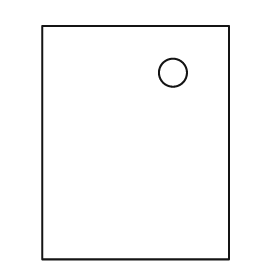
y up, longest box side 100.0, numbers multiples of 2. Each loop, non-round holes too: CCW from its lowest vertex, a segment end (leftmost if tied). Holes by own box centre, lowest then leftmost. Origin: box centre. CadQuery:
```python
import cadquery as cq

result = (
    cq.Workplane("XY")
    .moveTo(-40.0, -50.0)
    .lineTo(40.0, -50.0)
    .lineTo(40.0, 50.0)
    .lineTo(-40.0, 50.0)
    .close()
    .moveTo(16.0, 30.0)
    .circle(6.0)
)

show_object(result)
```